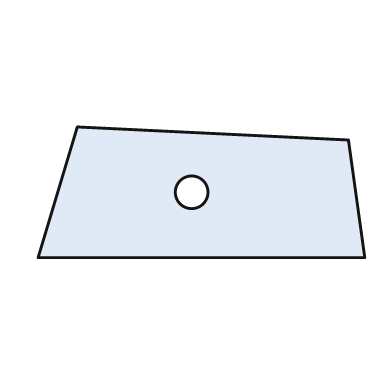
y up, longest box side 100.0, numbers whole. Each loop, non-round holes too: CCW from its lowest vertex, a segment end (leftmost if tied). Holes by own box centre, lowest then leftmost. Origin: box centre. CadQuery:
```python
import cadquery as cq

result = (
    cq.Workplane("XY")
    .moveTo(-50.0, -20.0)
    .lineTo(50.0, -20.0)
    .lineTo(45.0, 16.0)
    .lineTo(-38.0, 20.0)
    .close()
    .moveTo(-3.0, 0.0)
    .circle(5.0)
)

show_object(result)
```